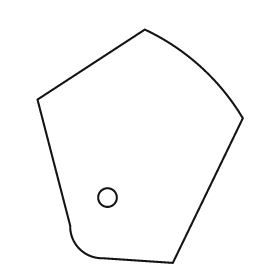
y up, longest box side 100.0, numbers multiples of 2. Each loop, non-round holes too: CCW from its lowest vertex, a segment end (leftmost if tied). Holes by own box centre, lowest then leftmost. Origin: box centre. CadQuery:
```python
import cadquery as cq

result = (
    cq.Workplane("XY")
    .moveTo(14.0, -50.0)
    .lineTo(44.0, 12.0)
    .threePointArc((26.0, 34.0), (2.0, 50.0))
    .lineTo(-44.0, 20.0)
    .lineTo(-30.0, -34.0)
    .threePointArc((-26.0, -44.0), (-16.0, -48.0))
    .close()
    .moveTo(-14.0, -22.0)
    .circle(4.0)
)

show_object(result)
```